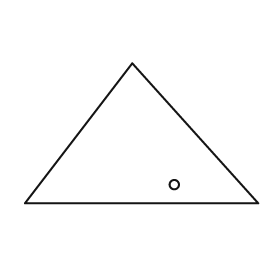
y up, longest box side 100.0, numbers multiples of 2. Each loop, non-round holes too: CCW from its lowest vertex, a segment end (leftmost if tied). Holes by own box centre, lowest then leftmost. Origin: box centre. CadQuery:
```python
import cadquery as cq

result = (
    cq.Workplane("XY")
    .moveTo(-50.0, -30.0)
    .lineTo(50.0, -30.0)
    .lineTo(-4.0, 30.0)
    .close()
    .moveTo(14.0, -22.0)
    .circle(2.0)
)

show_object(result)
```